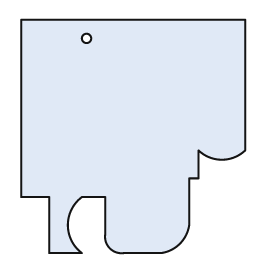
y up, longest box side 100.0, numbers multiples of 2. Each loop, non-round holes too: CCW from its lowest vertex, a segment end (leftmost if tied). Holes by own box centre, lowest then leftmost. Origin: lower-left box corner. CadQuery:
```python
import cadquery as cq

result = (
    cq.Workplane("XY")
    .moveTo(12.0, 0.0)
    .lineTo(26.0, 0.0)
    .threePointArc((20.0, 12.0), (26.0, 24.0))
    .lineTo(36.0, 24.0)
    .lineTo(36.0, 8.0)
    .threePointArc((38.0, 2.0), (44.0, 0.0))
    .lineTo(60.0, 0.0)
    .threePointArc((68.0, 4.0), (72.0, 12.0))
    .lineTo(72.0, 32.0)
    .lineTo(76.0, 32.0)
    .lineTo(76.0, 44.0)
    .threePointArc((86.0, 40.0), (96.0, 44.0))
    .lineTo(96.0, 100.0)
    .lineTo(0.0, 100.0)
    .lineTo(0.0, 24.0)
    .lineTo(12.0, 24.0)
    .close()
    .moveTo(28.0, 92.0)
    .circle(2.0)
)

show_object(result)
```